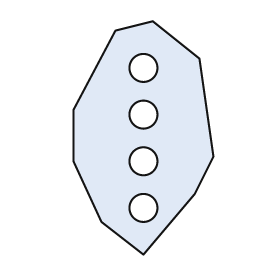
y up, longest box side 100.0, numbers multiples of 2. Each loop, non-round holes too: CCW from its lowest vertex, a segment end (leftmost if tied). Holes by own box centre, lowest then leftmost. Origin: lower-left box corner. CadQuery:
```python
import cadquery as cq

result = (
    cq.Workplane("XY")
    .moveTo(30.0, 0.0)
    .lineTo(52.0, 26.0)
    .lineTo(60.0, 42.0)
    .lineTo(54.0, 84.0)
    .lineTo(34.0, 100.0)
    .lineTo(18.0, 96.0)
    .lineTo(0.0, 62.0)
    .lineTo(0.0, 40.0)
    .lineTo(12.0, 14.0)
    .close()
    .moveTo(30.0, 20.0)
    .circle(6.0)
    .moveTo(30.0, 40.0)
    .circle(6.0)
    .moveTo(30.0, 60.0)
    .circle(6.0)
    .moveTo(30.0, 80.0)
    .circle(6.0)
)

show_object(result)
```